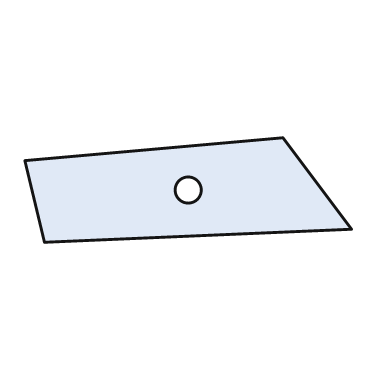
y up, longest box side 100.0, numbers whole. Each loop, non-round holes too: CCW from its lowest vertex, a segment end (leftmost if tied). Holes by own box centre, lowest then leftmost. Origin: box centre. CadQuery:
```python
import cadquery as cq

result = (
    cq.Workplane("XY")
    .moveTo(-44.0, -16.0)
    .lineTo(50.0, -12.0)
    .lineTo(29.0, 16.0)
    .lineTo(-50.0, 9.0)
    .close()
    .moveTo(0.0, 0.0)
    .circle(4.0)
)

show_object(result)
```